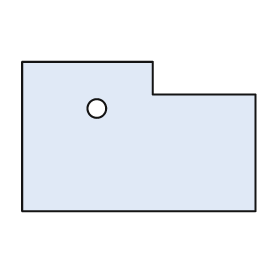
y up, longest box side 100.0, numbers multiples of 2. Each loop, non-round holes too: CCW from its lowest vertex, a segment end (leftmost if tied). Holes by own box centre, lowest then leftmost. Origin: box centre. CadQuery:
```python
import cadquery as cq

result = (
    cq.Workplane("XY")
    .moveTo(-50.0, -32.0)
    .lineTo(50.0, -32.0)
    .lineTo(50.0, 18.0)
    .lineTo(6.0, 18.0)
    .lineTo(6.0, 32.0)
    .lineTo(-50.0, 32.0)
    .close()
    .moveTo(-18.0, 12.0)
    .circle(4.0)
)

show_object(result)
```